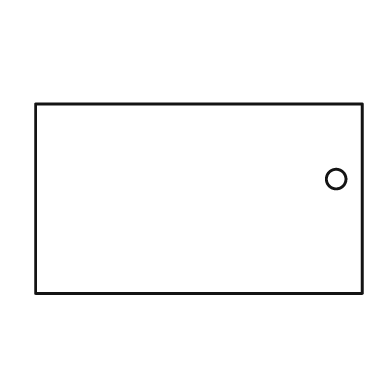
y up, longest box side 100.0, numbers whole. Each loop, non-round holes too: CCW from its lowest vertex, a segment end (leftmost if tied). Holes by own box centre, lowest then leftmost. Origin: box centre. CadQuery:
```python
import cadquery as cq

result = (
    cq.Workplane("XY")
    .moveTo(-50.0, -29.0)
    .lineTo(50.0, -29.0)
    .lineTo(50.0, 29.0)
    .lineTo(-50.0, 29.0)
    .close()
    .moveTo(42.0, 6.0)
    .circle(3.0)
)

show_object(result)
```